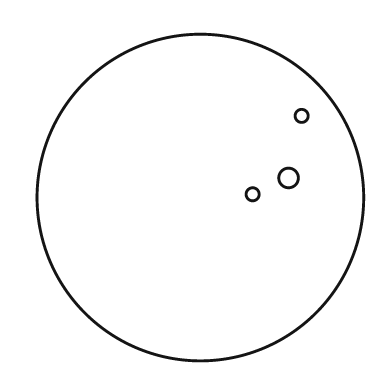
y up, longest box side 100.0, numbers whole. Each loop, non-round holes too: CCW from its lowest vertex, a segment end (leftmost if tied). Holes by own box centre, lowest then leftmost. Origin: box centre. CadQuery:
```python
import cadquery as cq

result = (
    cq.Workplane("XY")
    .moveTo(0.0, 0.0)
    .circle(50.0)
    .moveTo(16.0, 1.0)
    .circle(2.0)
    .moveTo(27.0, 6.0)
    .circle(3.0)
    .moveTo(31.0, 25.0)
    .circle(2.0)
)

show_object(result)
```